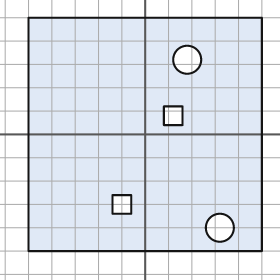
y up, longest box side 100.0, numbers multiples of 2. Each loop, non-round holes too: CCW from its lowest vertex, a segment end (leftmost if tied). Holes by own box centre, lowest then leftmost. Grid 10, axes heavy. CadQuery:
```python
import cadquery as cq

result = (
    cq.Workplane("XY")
    .moveTo(-50.0, -50.0)
    .lineTo(50.0, -50.0)
    .lineTo(50.0, 50.0)
    .lineTo(-50.0, 50.0)
    .close()
    .moveTo(32.0, -40.0)
    .circle(6.0)
    .moveTo(-14.0, -34.0)
    .lineTo(-6.0, -34.0)
    .lineTo(-6.0, -26.0)
    .lineTo(-14.0, -26.0)
    .close()
    .moveTo(8.0, 4.0)
    .lineTo(16.0, 4.0)
    .lineTo(16.0, 12.0)
    .lineTo(8.0, 12.0)
    .close()
    .moveTo(18.0, 32.0)
    .circle(6.0)
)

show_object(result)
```